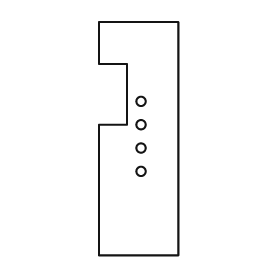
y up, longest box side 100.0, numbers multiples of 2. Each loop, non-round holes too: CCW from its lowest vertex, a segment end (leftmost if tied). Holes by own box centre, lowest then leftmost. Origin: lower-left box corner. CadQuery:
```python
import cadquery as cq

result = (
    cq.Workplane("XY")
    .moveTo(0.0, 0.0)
    .lineTo(34.0, 0.0)
    .lineTo(34.0, 100.0)
    .lineTo(0.0, 100.0)
    .lineTo(0.0, 82.0)
    .lineTo(12.0, 82.0)
    .lineTo(12.0, 56.0)
    .lineTo(0.0, 56.0)
    .close()
    .moveTo(18.0, 36.0)
    .circle(2.0)
    .moveTo(18.0, 46.0)
    .circle(2.0)
    .moveTo(18.0, 56.0)
    .circle(2.0)
    .moveTo(18.0, 66.0)
    .circle(2.0)
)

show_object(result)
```